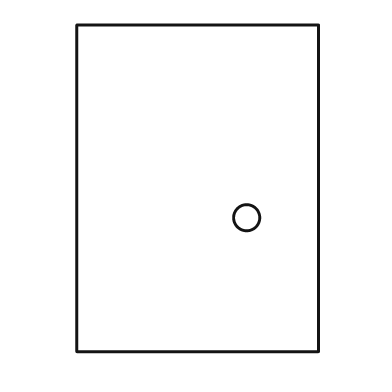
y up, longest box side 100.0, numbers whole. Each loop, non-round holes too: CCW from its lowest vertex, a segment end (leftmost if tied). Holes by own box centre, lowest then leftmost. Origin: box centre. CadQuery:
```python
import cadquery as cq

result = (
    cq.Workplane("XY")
    .moveTo(-37.0, -50.0)
    .lineTo(37.0, -50.0)
    .lineTo(37.0, 50.0)
    .lineTo(-37.0, 50.0)
    .close()
    .moveTo(15.0, -9.0)
    .circle(4.0)
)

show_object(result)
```